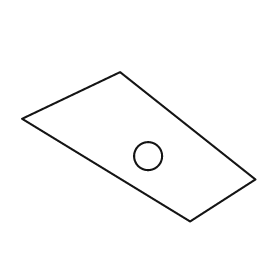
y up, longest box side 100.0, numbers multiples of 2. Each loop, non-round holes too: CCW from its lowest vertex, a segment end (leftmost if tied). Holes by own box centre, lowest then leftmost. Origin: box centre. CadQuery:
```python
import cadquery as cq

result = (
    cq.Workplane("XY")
    .moveTo(22.0, -32.0)
    .lineTo(50.0, -14.0)
    .lineTo(-8.0, 32.0)
    .lineTo(-50.0, 12.0)
    .close()
    .moveTo(4.0, -4.0)
    .circle(6.0)
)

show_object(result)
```